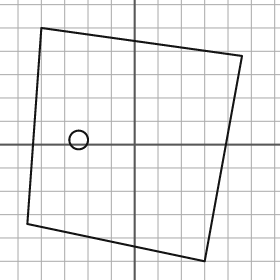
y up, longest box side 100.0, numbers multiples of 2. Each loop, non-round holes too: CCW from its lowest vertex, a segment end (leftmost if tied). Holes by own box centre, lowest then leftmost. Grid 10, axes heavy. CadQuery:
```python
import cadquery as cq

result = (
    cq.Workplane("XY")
    .moveTo(30.0, -50.0)
    .lineTo(46.0, 38.0)
    .lineTo(-40.0, 50.0)
    .lineTo(-46.0, -34.0)
    .close()
    .moveTo(-24.0, 2.0)
    .circle(4.0)
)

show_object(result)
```